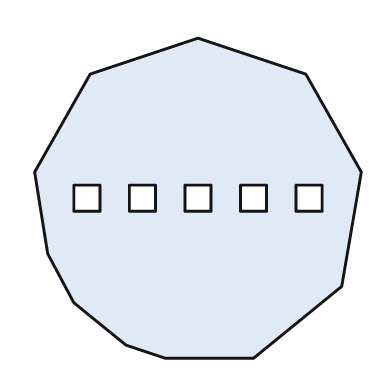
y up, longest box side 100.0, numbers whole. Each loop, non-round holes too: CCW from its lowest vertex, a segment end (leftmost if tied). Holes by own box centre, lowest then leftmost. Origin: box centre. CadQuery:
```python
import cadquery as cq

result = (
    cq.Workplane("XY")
    .moveTo(-10.0, -49.0)
    .lineTo(17.0, -49.0)
    .lineTo(44.0, -27.0)
    .lineTo(50.0, 8.0)
    .lineTo(33.0, 38.0)
    .lineTo(0.0, 49.0)
    .lineTo(-33.0, 38.0)
    .lineTo(-50.0, 8.0)
    .lineTo(-46.0, -17.0)
    .lineTo(-38.0, -32.0)
    .lineTo(-22.0, -45.0)
    .close()
    .moveTo(-38.0, -4.0)
    .lineTo(-30.0, -4.0)
    .lineTo(-30.0, 4.0)
    .lineTo(-38.0, 4.0)
    .close()
    .moveTo(-21.0, -4.0)
    .lineTo(-13.0, -4.0)
    .lineTo(-13.0, 4.0)
    .lineTo(-21.0, 4.0)
    .close()
    .moveTo(-4.0, -4.0)
    .lineTo(4.0, -4.0)
    .lineTo(4.0, 4.0)
    .lineTo(-4.0, 4.0)
    .close()
    .moveTo(13.0, -4.0)
    .lineTo(21.0, -4.0)
    .lineTo(21.0, 4.0)
    .lineTo(13.0, 4.0)
    .close()
    .moveTo(30.0, -4.0)
    .lineTo(38.0, -4.0)
    .lineTo(38.0, 4.0)
    .lineTo(30.0, 4.0)
    .close()
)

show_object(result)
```